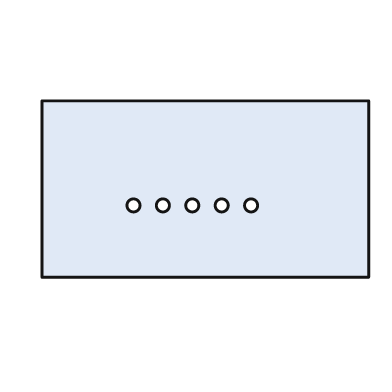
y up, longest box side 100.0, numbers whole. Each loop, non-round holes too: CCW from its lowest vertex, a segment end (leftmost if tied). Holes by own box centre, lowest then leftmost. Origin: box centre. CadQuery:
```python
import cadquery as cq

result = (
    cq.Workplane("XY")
    .moveTo(-50.0, -27.0)
    .lineTo(50.0, -27.0)
    .lineTo(50.0, 27.0)
    .lineTo(-50.0, 27.0)
    .close()
    .moveTo(-22.0, -5.0)
    .circle(2.0)
    .moveTo(-13.0, -5.0)
    .circle(2.0)
    .moveTo(-4.0, -5.0)
    .circle(2.0)
    .moveTo(5.0, -5.0)
    .circle(2.0)
    .moveTo(14.0, -5.0)
    .circle(2.0)
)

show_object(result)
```